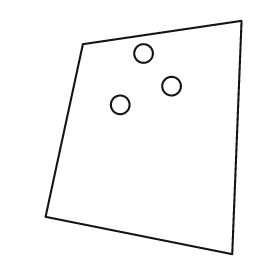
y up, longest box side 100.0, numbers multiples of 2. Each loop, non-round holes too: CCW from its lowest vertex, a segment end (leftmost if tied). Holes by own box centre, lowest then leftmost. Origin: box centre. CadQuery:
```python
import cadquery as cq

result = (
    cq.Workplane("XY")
    .moveTo(38.0, -50.0)
    .lineTo(42.0, 50.0)
    .lineTo(-26.0, 40.0)
    .lineTo(-42.0, -34.0)
    .close()
    .moveTo(-10.0, 14.0)
    .circle(4.0)
    .moveTo(12.0, 22.0)
    .circle(4.0)
    .moveTo(0.0, 36.0)
    .circle(4.0)
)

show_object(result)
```